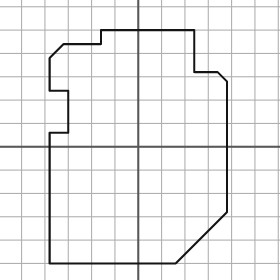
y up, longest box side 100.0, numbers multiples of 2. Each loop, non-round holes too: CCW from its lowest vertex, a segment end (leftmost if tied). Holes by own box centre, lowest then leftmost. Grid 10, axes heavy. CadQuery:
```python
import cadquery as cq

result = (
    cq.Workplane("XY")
    .moveTo(-38.0, -50.0)
    .lineTo(16.0, -50.0)
    .lineTo(38.0, -28.0)
    .lineTo(38.0, 28.0)
    .lineTo(34.0, 32.0)
    .lineTo(24.0, 32.0)
    .lineTo(24.0, 50.0)
    .lineTo(-16.0, 50.0)
    .lineTo(-16.0, 44.0)
    .lineTo(-32.0, 44.0)
    .lineTo(-38.0, 38.0)
    .lineTo(-38.0, 24.0)
    .lineTo(-30.0, 24.0)
    .lineTo(-30.0, 6.0)
    .lineTo(-38.0, 6.0)
    .close()
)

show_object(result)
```